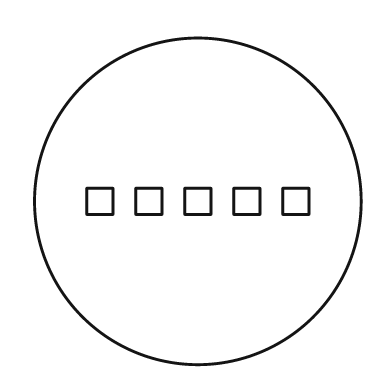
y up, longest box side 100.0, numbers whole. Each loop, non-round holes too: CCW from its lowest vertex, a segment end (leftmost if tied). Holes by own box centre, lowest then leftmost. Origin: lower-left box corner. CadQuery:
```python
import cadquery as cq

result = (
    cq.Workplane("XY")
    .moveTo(50.0, 50.0)
    .circle(50.0)
    .moveTo(16.0, 46.0)
    .lineTo(24.0, 46.0)
    .lineTo(24.0, 54.0)
    .lineTo(16.0, 54.0)
    .close()
    .moveTo(31.0, 46.0)
    .lineTo(39.0, 46.0)
    .lineTo(39.0, 54.0)
    .lineTo(31.0, 54.0)
    .close()
    .moveTo(46.0, 46.0)
    .lineTo(54.0, 46.0)
    .lineTo(54.0, 54.0)
    .lineTo(46.0, 54.0)
    .close()
    .moveTo(61.0, 46.0)
    .lineTo(69.0, 46.0)
    .lineTo(69.0, 54.0)
    .lineTo(61.0, 54.0)
    .close()
    .moveTo(76.0, 46.0)
    .lineTo(84.0, 46.0)
    .lineTo(84.0, 54.0)
    .lineTo(76.0, 54.0)
    .close()
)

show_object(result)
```